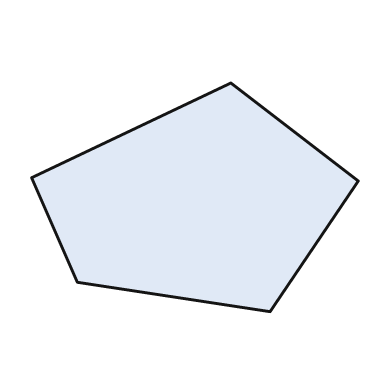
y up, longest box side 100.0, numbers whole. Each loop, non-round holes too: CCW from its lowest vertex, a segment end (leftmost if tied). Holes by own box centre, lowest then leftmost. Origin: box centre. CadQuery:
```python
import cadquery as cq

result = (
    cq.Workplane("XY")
    .moveTo(23.0, -35.0)
    .lineTo(50.0, 5.0)
    .lineTo(11.0, 35.0)
    .lineTo(-50.0, 6.0)
    .lineTo(-36.0, -26.0)
    .close()
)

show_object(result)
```